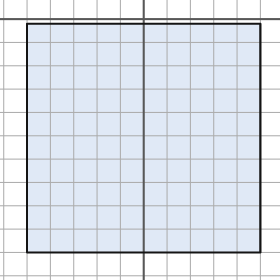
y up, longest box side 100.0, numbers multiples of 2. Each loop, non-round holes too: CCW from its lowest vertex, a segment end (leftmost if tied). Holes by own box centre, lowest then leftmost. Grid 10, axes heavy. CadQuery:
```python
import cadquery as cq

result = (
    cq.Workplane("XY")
    .moveTo(-50.0, -100.0)
    .lineTo(50.0, -100.0)
    .lineTo(50.0, -2.0)
    .lineTo(-50.0, -2.0)
    .close()
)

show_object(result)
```